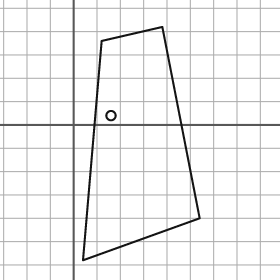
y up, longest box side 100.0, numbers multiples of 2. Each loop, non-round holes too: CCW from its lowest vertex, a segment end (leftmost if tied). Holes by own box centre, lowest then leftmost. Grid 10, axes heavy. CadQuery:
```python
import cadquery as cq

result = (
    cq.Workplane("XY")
    .moveTo(4.0, -58.0)
    .lineTo(54.0, -40.0)
    .lineTo(38.0, 42.0)
    .lineTo(12.0, 36.0)
    .close()
    .moveTo(16.0, 4.0)
    .circle(2.0)
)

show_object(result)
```